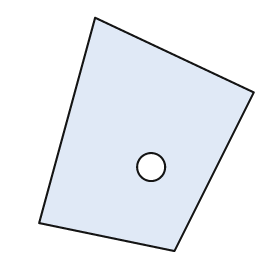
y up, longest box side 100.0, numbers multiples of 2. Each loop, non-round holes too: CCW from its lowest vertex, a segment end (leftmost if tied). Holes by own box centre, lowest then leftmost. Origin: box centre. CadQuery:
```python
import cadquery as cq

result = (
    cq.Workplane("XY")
    .moveTo(12.0, -50.0)
    .lineTo(46.0, 18.0)
    .lineTo(-22.0, 50.0)
    .lineTo(-46.0, -38.0)
    .close()
    .moveTo(2.0, -14.0)
    .circle(6.0)
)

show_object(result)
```